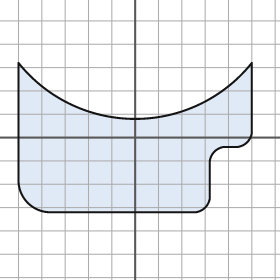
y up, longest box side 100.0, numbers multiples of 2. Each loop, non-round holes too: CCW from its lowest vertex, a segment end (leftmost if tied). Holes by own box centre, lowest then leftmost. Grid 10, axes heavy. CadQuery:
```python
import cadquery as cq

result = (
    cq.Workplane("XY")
    .moveTo(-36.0, -32.0)
    .lineTo(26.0, -32.0)
    .threePointArc((30.0, -30.0), (32.0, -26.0))
    .lineTo(32.0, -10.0)
    .threePointArc((34.0, -6.0), (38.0, -4.0))
    .lineTo(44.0, -4.0)
    .threePointArc((48.0, -2.0), (50.0, 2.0))
    .lineTo(50.0, 32.0)
    .threePointArc((0.0, 8.0), (-50.0, 32.0))
    .lineTo(-50.0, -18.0)
    .threePointArc((-46.0, -28.0), (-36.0, -32.0))
    .close()
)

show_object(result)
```